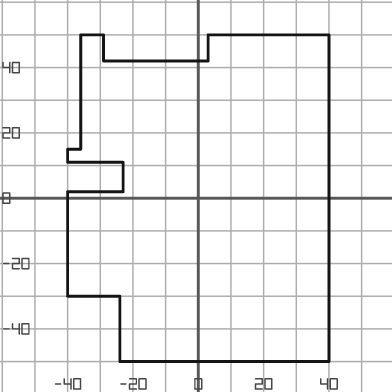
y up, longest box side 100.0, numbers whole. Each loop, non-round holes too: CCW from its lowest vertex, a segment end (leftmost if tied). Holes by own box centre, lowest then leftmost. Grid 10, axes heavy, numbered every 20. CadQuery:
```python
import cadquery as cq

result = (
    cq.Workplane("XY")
    .moveTo(-24.0, -50.0)
    .lineTo(40.0, -50.0)
    .lineTo(40.0, 50.0)
    .lineTo(3.0, 50.0)
    .lineTo(3.0, 42.0)
    .lineTo(-29.0, 42.0)
    .lineTo(-29.0, 50.0)
    .lineTo(-36.0, 50.0)
    .lineTo(-36.0, 15.0)
    .lineTo(-40.0, 15.0)
    .lineTo(-40.0, 11.0)
    .lineTo(-23.0, 11.0)
    .lineTo(-23.0, 2.0)
    .lineTo(-40.0, 2.0)
    .lineTo(-40.0, -30.0)
    .lineTo(-24.0, -30.0)
    .close()
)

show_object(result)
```